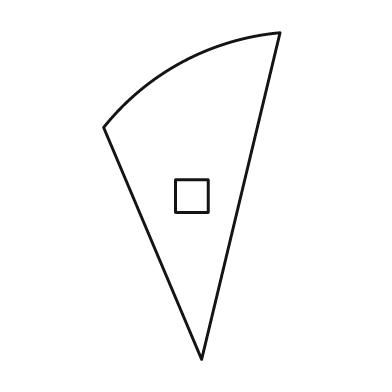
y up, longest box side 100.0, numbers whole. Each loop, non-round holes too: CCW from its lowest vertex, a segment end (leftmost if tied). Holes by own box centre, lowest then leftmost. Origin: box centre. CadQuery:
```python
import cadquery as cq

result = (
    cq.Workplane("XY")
    .moveTo(3.0, -50.0)
    .lineTo(27.0, 50.0)
    .threePointArc((-3.0, 41.0), (-27.0, 21.0))
    .close()
    .moveTo(-5.0, -5.0)
    .lineTo(5.0, -5.0)
    .lineTo(5.0, 5.0)
    .lineTo(-5.0, 5.0)
    .close()
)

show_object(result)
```